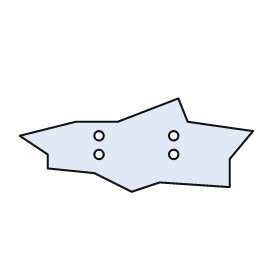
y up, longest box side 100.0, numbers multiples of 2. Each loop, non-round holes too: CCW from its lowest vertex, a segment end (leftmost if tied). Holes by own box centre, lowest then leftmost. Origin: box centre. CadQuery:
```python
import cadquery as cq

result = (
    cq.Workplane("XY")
    .moveTo(-2.0, -20.0)
    .lineTo(10.0, -16.0)
    .lineTo(40.0, -18.0)
    .lineTo(40.0, -6.0)
    .lineTo(50.0, 6.0)
    .lineTo(22.0, 10.0)
    .lineTo(18.0, 20.0)
    .lineTo(-8.0, 10.0)
    .lineTo(-26.0, 10.0)
    .lineTo(-50.0, 4.0)
    .lineTo(-38.0, -4.0)
    .lineTo(-38.0, -10.0)
    .lineTo(-18.0, -12.0)
    .close()
    .moveTo(-16.0, -4.0)
    .circle(2.0)
    .moveTo(16.0, -4.0)
    .circle(2.0)
    .moveTo(-16.0, 4.0)
    .circle(2.0)
    .moveTo(16.0, 4.0)
    .circle(2.0)
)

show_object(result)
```